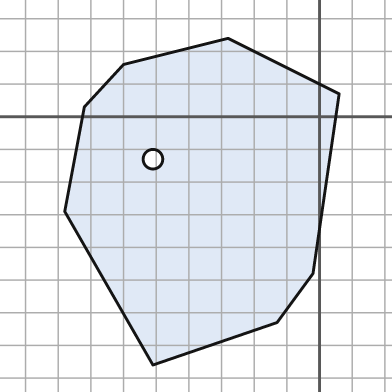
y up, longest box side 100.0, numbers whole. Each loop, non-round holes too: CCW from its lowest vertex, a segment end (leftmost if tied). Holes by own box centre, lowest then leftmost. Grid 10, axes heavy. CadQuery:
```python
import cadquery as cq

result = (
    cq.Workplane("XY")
    .moveTo(-51.0, -76.0)
    .lineTo(-13.0, -63.0)
    .lineTo(-2.0, -48.0)
    .lineTo(6.0, 7.0)
    .lineTo(-28.0, 24.0)
    .lineTo(-60.0, 16.0)
    .lineTo(-72.0, 3.0)
    .lineTo(-78.0, -29.0)
    .close()
    .moveTo(-51.0, -13.0)
    .circle(3.0)
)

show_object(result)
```